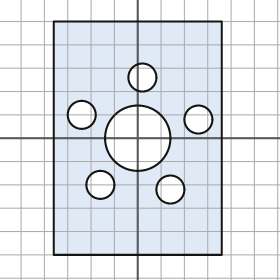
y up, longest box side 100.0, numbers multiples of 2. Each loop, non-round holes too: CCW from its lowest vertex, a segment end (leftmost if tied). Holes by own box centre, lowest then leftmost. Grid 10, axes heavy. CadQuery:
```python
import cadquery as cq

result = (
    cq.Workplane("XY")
    .moveTo(-36.0, -50.0)
    .lineTo(36.0, -50.0)
    .lineTo(36.0, 50.0)
    .lineTo(-36.0, 50.0)
    .close()
    .moveTo(14.0, -22.0)
    .circle(6.0)
    .moveTo(-16.0, -20.0)
    .circle(6.0)
    .moveTo(0.0, 0.0)
    .circle(14.0)
    .moveTo(26.0, 8.0)
    .circle(6.0)
    .moveTo(-24.0, 10.0)
    .circle(6.0)
    .moveTo(2.0, 26.0)
    .circle(6.0)
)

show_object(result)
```